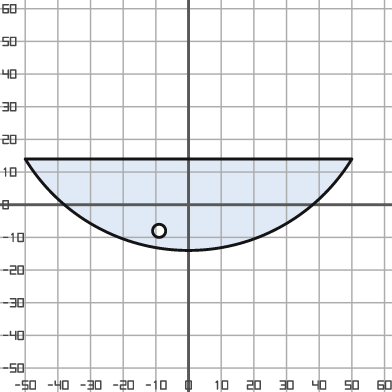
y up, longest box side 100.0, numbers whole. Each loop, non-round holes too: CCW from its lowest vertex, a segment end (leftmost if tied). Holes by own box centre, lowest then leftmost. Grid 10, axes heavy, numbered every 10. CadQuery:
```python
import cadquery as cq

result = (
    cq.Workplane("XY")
    .moveTo(-50.0, 14.0)
    .threePointArc((0.0, -14.0), (50.0, 14.0))
    .close()
    .moveTo(-9.0, -8.0)
    .circle(2.0)
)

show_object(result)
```